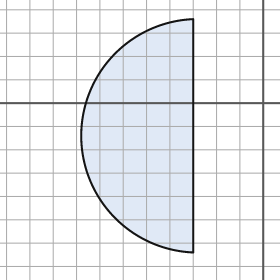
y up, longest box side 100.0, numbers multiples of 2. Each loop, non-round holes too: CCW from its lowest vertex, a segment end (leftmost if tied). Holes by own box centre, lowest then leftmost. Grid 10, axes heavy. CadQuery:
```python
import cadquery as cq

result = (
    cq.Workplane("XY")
    .moveTo(-30.0, -64.0)
    .lineTo(-30.0, 36.0)
    .threePointArc((-78.0, -14.0), (-30.0, -64.0))
    .close()
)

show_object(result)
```